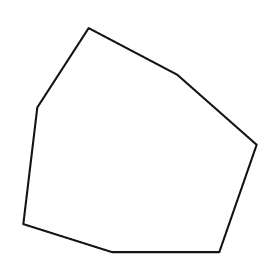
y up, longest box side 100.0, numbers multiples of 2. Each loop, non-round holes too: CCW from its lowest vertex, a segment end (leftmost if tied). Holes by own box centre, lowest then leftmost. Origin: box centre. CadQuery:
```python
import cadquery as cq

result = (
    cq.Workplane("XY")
    .moveTo(-12.0, -48.0)
    .lineTo(34.0, -48.0)
    .lineTo(50.0, -2.0)
    .lineTo(16.0, 28.0)
    .lineTo(-22.0, 48.0)
    .lineTo(-44.0, 14.0)
    .lineTo(-50.0, -36.0)
    .close()
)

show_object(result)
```